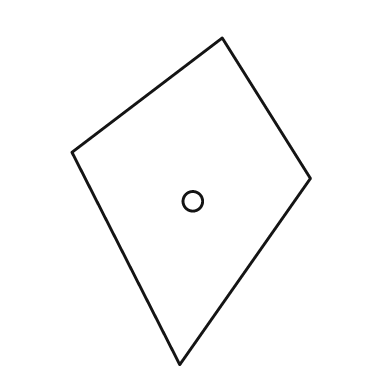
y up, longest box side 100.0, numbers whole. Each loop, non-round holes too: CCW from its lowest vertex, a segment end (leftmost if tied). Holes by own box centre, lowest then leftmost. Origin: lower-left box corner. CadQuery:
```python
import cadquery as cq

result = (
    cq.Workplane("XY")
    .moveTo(33.0, 0.0)
    .lineTo(73.0, 57.0)
    .lineTo(46.0, 100.0)
    .lineTo(0.0, 65.0)
    .close()
    .moveTo(37.0, 50.0)
    .circle(3.0)
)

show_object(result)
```